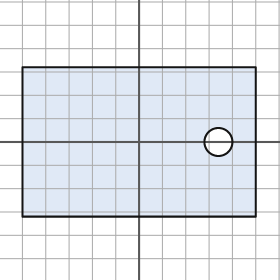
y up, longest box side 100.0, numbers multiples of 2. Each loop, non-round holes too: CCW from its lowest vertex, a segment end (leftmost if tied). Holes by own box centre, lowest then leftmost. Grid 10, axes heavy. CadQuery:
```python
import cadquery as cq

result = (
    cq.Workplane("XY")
    .moveTo(-50.0, -32.0)
    .lineTo(50.0, -32.0)
    .lineTo(50.0, 32.0)
    .lineTo(-50.0, 32.0)
    .close()
    .moveTo(34.0, 0.0)
    .circle(6.0)
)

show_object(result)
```